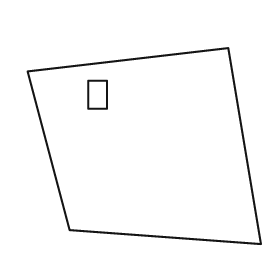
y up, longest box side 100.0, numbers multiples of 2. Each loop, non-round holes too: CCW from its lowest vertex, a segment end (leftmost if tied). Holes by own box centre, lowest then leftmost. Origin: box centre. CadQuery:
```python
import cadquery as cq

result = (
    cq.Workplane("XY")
    .moveTo(50.0, -42.0)
    .lineTo(36.0, 42.0)
    .lineTo(-50.0, 32.0)
    .lineTo(-32.0, -36.0)
    .close()
    .moveTo(-24.0, 16.0)
    .lineTo(-16.0, 16.0)
    .lineTo(-16.0, 28.0)
    .lineTo(-24.0, 28.0)
    .close()
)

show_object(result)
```